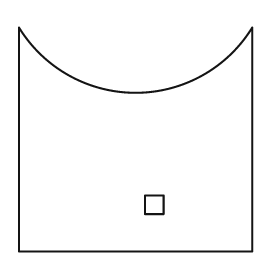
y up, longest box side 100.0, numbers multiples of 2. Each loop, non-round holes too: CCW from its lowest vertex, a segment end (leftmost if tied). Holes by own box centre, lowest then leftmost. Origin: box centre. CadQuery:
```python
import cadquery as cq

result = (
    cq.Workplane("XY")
    .moveTo(-50.0, -48.0)
    .lineTo(50.0, -48.0)
    .lineTo(50.0, 48.0)
    .threePointArc((0.0, 20.0), (-50.0, 48.0))
    .close()
    .moveTo(4.0, -32.0)
    .lineTo(12.0, -32.0)
    .lineTo(12.0, -24.0)
    .lineTo(4.0, -24.0)
    .close()
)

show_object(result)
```